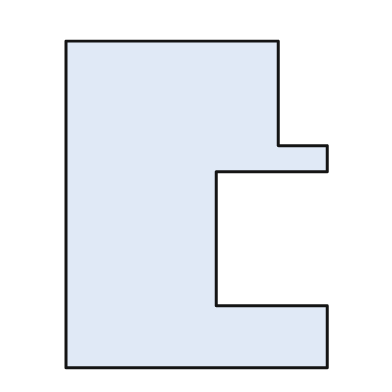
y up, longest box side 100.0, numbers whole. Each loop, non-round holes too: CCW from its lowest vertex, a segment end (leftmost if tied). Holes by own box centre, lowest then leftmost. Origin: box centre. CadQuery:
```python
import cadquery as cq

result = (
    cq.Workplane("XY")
    .moveTo(-40.0, -50.0)
    .lineTo(40.0, -50.0)
    .lineTo(40.0, -31.0)
    .lineTo(6.0, -31.0)
    .lineTo(6.0, 10.0)
    .lineTo(40.0, 10.0)
    .lineTo(40.0, 18.0)
    .lineTo(25.0, 18.0)
    .lineTo(25.0, 50.0)
    .lineTo(-40.0, 50.0)
    .close()
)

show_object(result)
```